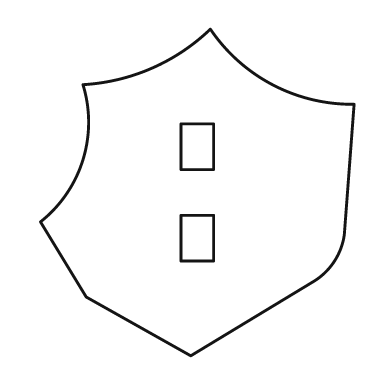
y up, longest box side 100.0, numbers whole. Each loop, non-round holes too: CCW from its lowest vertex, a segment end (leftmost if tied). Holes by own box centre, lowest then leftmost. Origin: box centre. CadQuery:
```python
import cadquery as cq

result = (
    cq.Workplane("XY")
    .moveTo(-2.0, -50.0)
    .lineTo(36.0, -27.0)
    .threePointArc((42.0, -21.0), (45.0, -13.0))
    .lineTo(48.0, 27.0)
    .threePointArc((23.0, 33.0), (4.0, 50.0))
    .threePointArc((-14.0, 38.0), (-35.0, 33.0))
    .threePointArc((-35.0, 10.0), (-48.0, -9.0))
    .lineTo(-34.0, -32.0)
    .close()
    .moveTo(-5.0, -21.0)
    .lineTo(5.0, -21.0)
    .lineTo(5.0, -7.0)
    .lineTo(-5.0, -7.0)
    .close()
    .moveTo(-5.0, 7.0)
    .lineTo(5.0, 7.0)
    .lineTo(5.0, 21.0)
    .lineTo(-5.0, 21.0)
    .close()
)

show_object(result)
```